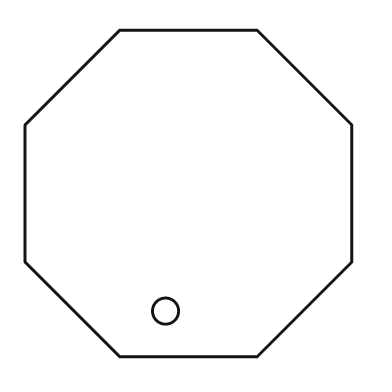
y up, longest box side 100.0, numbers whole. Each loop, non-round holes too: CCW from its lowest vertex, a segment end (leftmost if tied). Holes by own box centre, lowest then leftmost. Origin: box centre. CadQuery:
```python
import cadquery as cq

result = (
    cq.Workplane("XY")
    .moveTo(-21.0, -50.0)
    .lineTo(21.0, -50.0)
    .lineTo(50.0, -21.0)
    .lineTo(50.0, 21.0)
    .lineTo(21.0, 50.0)
    .lineTo(-21.0, 50.0)
    .lineTo(-50.0, 21.0)
    .lineTo(-50.0, -21.0)
    .close()
    .moveTo(-7.0, -36.0)
    .circle(4.0)
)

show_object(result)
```